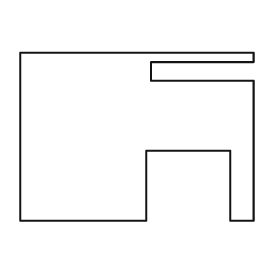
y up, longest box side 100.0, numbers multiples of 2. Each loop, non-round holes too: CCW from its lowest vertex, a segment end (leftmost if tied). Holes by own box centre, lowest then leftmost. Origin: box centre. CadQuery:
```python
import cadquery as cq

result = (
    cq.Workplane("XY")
    .moveTo(-50.0, -36.0)
    .lineTo(4.0, -36.0)
    .lineTo(4.0, -6.0)
    .lineTo(40.0, -6.0)
    .lineTo(40.0, -36.0)
    .lineTo(50.0, -36.0)
    .lineTo(50.0, 24.0)
    .lineTo(6.0, 24.0)
    .lineTo(6.0, 32.0)
    .lineTo(50.0, 32.0)
    .lineTo(50.0, 36.0)
    .lineTo(-50.0, 36.0)
    .close()
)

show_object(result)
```